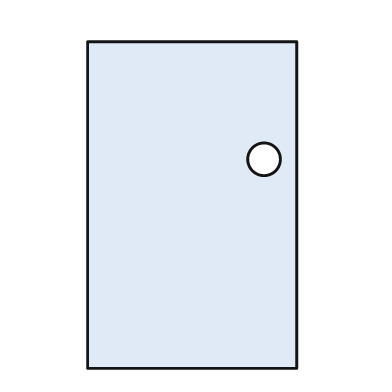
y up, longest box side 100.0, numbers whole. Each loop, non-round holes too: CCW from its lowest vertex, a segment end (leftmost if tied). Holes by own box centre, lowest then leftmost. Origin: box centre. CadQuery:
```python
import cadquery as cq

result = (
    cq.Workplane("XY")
    .moveTo(-32.0, -50.0)
    .lineTo(32.0, -50.0)
    .lineTo(32.0, 50.0)
    .lineTo(-32.0, 50.0)
    .close()
    .moveTo(22.0, 14.0)
    .circle(5.0)
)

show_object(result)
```